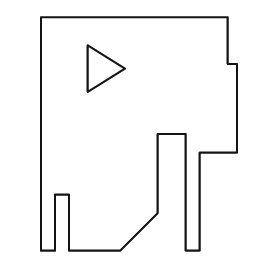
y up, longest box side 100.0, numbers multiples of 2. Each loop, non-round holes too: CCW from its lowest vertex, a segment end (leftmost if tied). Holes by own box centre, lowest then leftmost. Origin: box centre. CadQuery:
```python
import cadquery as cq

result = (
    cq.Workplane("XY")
    .moveTo(-42.0, -50.0)
    .lineTo(-36.0, -50.0)
    .lineTo(-36.0, -26.0)
    .lineTo(-30.0, -26.0)
    .lineTo(-30.0, -50.0)
    .lineTo(-8.0, -50.0)
    .lineTo(8.0, -34.0)
    .lineTo(8.0, 0.0)
    .lineTo(20.0, 0.0)
    .lineTo(20.0, -50.0)
    .lineTo(26.0, -50.0)
    .lineTo(26.0, -8.0)
    .lineTo(42.0, -8.0)
    .lineTo(42.0, 30.0)
    .lineTo(38.0, 30.0)
    .lineTo(38.0, 50.0)
    .lineTo(-42.0, 50.0)
    .close()
    .moveTo(-22.0, 18.0)
    .lineTo(-6.0, 28.0)
    .lineTo(-22.0, 38.0)
    .close()
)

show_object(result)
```